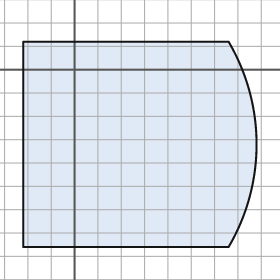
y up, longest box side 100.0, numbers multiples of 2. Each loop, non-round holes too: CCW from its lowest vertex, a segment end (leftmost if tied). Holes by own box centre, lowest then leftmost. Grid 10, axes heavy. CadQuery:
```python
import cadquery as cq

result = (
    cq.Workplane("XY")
    .moveTo(-22.0, -76.0)
    .lineTo(66.0, -76.0)
    .threePointArc((78.0, -32.0), (66.0, 12.0))
    .lineTo(-22.0, 12.0)
    .close()
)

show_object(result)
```